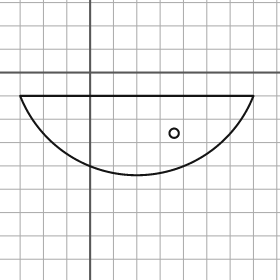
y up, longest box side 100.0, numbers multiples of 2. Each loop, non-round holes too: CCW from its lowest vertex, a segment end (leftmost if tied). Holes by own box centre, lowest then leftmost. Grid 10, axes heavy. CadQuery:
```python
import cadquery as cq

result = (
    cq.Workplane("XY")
    .moveTo(-30.0, -10.0)
    .threePointArc((20.0, -44.0), (70.0, -10.0))
    .close()
    .moveTo(36.0, -26.0)
    .circle(2.0)
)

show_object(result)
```